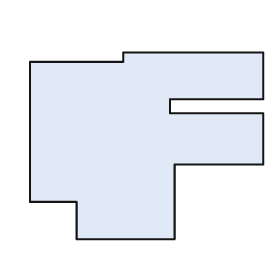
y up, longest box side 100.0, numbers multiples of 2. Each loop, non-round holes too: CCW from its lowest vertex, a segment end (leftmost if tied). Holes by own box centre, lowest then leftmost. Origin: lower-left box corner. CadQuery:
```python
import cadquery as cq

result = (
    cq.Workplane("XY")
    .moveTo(20.0, 0.0)
    .lineTo(62.0, 0.0)
    .lineTo(62.0, 32.0)
    .lineTo(100.0, 32.0)
    .lineTo(100.0, 54.0)
    .lineTo(60.0, 54.0)
    .lineTo(60.0, 60.0)
    .lineTo(100.0, 60.0)
    .lineTo(100.0, 80.0)
    .lineTo(40.0, 80.0)
    .lineTo(40.0, 76.0)
    .lineTo(0.0, 76.0)
    .lineTo(0.0, 16.0)
    .lineTo(20.0, 16.0)
    .close()
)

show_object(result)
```